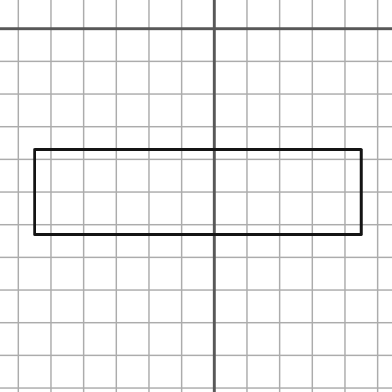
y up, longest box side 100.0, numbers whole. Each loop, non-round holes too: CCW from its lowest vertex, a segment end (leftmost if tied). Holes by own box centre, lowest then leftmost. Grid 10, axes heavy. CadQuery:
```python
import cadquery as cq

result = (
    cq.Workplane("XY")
    .moveTo(-55.0, -63.0)
    .lineTo(45.0, -63.0)
    .lineTo(45.0, -37.0)
    .lineTo(-55.0, -37.0)
    .close()
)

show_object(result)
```